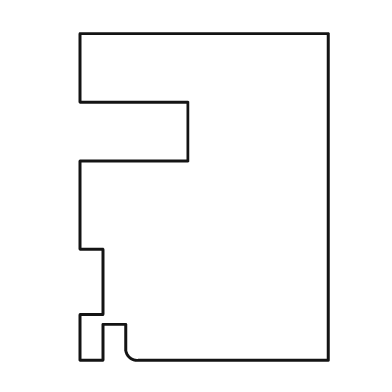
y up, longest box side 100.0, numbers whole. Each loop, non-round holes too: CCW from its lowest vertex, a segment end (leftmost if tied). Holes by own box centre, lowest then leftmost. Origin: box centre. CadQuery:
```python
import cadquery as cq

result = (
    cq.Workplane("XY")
    .moveTo(-38.0, -50.0)
    .lineTo(-31.0, -50.0)
    .lineTo(-31.0, -39.0)
    .lineTo(-24.0, -39.0)
    .lineTo(-24.0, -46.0)
    .threePointArc((-23.0, -49.0), (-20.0, -50.0))
    .lineTo(38.0, -50.0)
    .lineTo(38.0, 50.0)
    .lineTo(-38.0, 50.0)
    .lineTo(-38.0, 29.0)
    .lineTo(-5.0, 29.0)
    .lineTo(-5.0, 11.0)
    .lineTo(-38.0, 11.0)
    .lineTo(-38.0, -16.0)
    .lineTo(-31.0, -16.0)
    .lineTo(-31.0, -36.0)
    .lineTo(-38.0, -36.0)
    .close()
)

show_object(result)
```